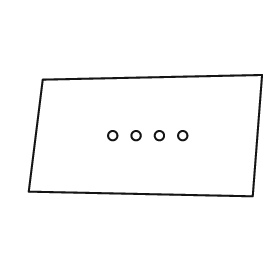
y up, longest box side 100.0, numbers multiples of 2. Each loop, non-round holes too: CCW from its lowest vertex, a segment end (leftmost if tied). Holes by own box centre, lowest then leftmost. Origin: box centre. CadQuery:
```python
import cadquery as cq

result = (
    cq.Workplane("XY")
    .moveTo(46.0, -26.0)
    .lineTo(50.0, 26.0)
    .lineTo(-44.0, 24.0)
    .lineTo(-50.0, -24.0)
    .close()
    .moveTo(-14.0, 0.0)
    .circle(2.0)
    .moveTo(-4.0, 0.0)
    .circle(2.0)
    .moveTo(6.0, 0.0)
    .circle(2.0)
    .moveTo(16.0, 0.0)
    .circle(2.0)
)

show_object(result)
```